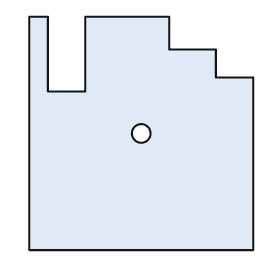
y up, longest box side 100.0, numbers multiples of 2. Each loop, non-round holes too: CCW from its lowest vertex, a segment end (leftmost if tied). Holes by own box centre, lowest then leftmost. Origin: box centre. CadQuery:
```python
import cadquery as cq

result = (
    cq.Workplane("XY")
    .moveTo(-48.0, -50.0)
    .lineTo(48.0, -50.0)
    .lineTo(48.0, 24.0)
    .lineTo(32.0, 24.0)
    .lineTo(32.0, 36.0)
    .lineTo(12.0, 36.0)
    .lineTo(12.0, 50.0)
    .lineTo(-24.0, 50.0)
    .lineTo(-24.0, 18.0)
    .lineTo(-40.0, 18.0)
    .lineTo(-40.0, 50.0)
    .lineTo(-48.0, 50.0)
    .close()
    .moveTo(0.0, 0.0)
    .circle(4.0)
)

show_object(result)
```